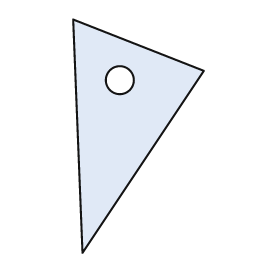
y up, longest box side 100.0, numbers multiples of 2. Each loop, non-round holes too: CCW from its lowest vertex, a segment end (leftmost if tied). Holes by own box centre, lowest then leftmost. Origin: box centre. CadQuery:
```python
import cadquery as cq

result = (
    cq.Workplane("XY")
    .moveTo(-24.0, -50.0)
    .lineTo(28.0, 28.0)
    .lineTo(-28.0, 50.0)
    .close()
    .moveTo(-8.0, 24.0)
    .circle(6.0)
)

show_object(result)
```